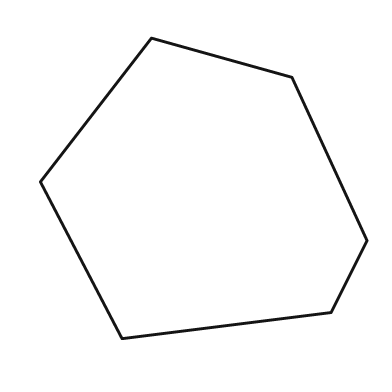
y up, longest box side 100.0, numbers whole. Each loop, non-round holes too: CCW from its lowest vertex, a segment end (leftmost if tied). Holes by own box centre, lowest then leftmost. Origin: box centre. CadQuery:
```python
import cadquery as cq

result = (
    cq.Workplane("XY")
    .moveTo(-25.0, -46.0)
    .lineTo(39.0, -38.0)
    .lineTo(50.0, -16.0)
    .lineTo(27.0, 34.0)
    .lineTo(-16.0, 46.0)
    .lineTo(-50.0, 2.0)
    .close()
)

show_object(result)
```